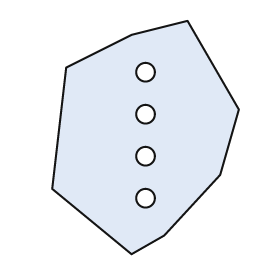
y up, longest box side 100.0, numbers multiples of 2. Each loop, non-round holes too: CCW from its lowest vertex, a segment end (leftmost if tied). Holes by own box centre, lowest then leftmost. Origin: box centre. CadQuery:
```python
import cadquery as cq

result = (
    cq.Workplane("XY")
    .moveTo(-6.0, -50.0)
    .lineTo(8.0, -42.0)
    .lineTo(32.0, -16.0)
    .lineTo(40.0, 12.0)
    .lineTo(18.0, 50.0)
    .lineTo(-6.0, 44.0)
    .lineTo(-34.0, 30.0)
    .lineTo(-40.0, -22.0)
    .close()
    .moveTo(0.0, -26.0)
    .circle(4.0)
    .moveTo(0.0, -8.0)
    .circle(4.0)
    .moveTo(0.0, 10.0)
    .circle(4.0)
    .moveTo(0.0, 28.0)
    .circle(4.0)
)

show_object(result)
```